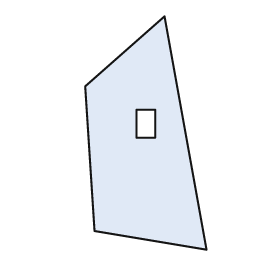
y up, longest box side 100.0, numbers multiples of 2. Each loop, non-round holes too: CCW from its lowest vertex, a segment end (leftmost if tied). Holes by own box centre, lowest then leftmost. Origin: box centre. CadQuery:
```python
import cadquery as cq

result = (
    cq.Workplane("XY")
    .moveTo(26.0, -50.0)
    .lineTo(8.0, 50.0)
    .lineTo(-26.0, 20.0)
    .lineTo(-22.0, -42.0)
    .close()
    .moveTo(-4.0, -2.0)
    .lineTo(4.0, -2.0)
    .lineTo(4.0, 10.0)
    .lineTo(-4.0, 10.0)
    .close()
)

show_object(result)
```